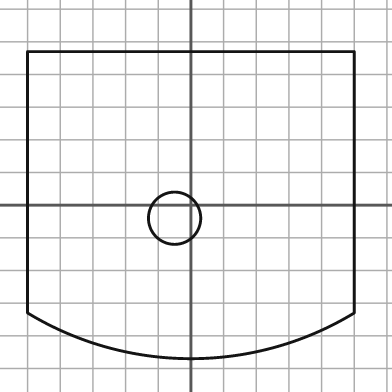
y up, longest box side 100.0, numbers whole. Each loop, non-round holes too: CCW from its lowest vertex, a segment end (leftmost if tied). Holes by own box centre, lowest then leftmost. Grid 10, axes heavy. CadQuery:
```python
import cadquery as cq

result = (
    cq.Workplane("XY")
    .moveTo(-50.0, -33.0)
    .threePointArc((0.0, -47.0), (50.0, -33.0))
    .lineTo(50.0, 47.0)
    .lineTo(-50.0, 47.0)
    .close()
    .moveTo(-5.0, -4.0)
    .circle(8.0)
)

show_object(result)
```